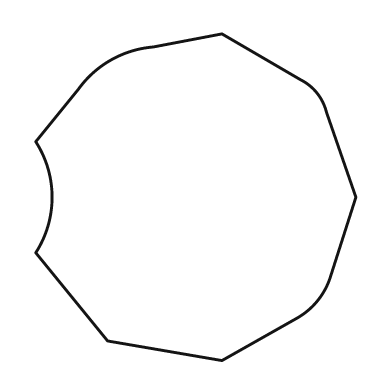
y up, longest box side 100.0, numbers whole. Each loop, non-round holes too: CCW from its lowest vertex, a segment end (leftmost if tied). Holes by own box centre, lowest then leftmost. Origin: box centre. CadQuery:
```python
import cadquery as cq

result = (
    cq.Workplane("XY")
    .moveTo(8.0, -50.0)
    .lineTo(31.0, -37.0)
    .threePointArc((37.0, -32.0), (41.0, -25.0))
    .lineTo(49.0, 0.0)
    .lineTo(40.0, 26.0)
    .threePointArc((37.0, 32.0), (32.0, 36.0))
    .lineTo(8.0, 50.0)
    .lineTo(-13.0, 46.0)
    .threePointArc((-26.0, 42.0), (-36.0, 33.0))
    .lineTo(-49.0, 17.0)
    .threePointArc((-44.0, 0.0), (-49.0, -17.0))
    .lineTo(-27.0, -44.0)
    .close()
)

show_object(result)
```